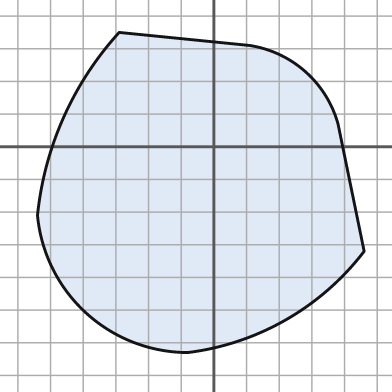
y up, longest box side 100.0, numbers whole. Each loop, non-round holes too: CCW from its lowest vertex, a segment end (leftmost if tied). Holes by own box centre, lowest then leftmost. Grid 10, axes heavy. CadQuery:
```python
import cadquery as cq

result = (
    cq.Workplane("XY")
    .moveTo(-8.0, -63.0)
    .threePointArc((22.0, -53.0), (46.0, -32.0))
    .lineTo(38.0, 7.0)
    .threePointArc((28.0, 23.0), (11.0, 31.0))
    .lineTo(-29.0, 35.0)
    .threePointArc((-46.0, 9.0), (-54.0, -21.0))
    .threePointArc((-39.0, -51.0), (-8.0, -63.0))
    .close()
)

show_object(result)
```